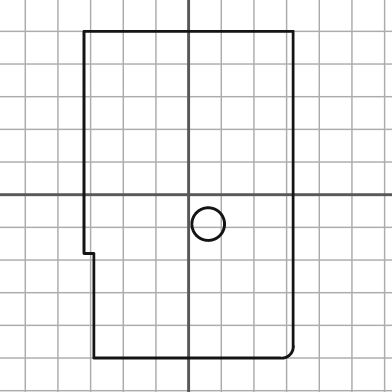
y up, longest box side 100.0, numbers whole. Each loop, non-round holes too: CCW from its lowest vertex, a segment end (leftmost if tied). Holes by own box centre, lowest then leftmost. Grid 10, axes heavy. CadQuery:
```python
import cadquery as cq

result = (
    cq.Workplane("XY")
    .moveTo(-29.0, -50.0)
    .lineTo(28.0, -50.0)
    .threePointArc((31.0, -49.0), (32.0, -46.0))
    .lineTo(32.0, 50.0)
    .lineTo(-32.0, 50.0)
    .lineTo(-32.0, -18.0)
    .lineTo(-29.0, -18.0)
    .close()
    .moveTo(6.0, -9.0)
    .circle(5.0)
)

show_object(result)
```